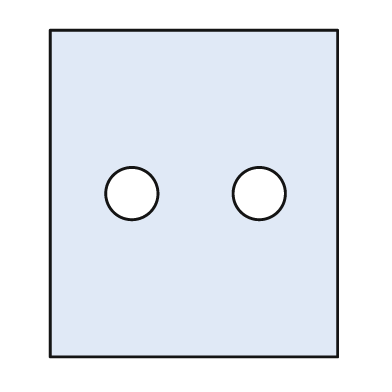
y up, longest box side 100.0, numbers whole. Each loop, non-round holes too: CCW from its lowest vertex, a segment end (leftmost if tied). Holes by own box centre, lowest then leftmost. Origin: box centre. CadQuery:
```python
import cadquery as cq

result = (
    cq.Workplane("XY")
    .moveTo(-44.0, -50.0)
    .lineTo(44.0, -50.0)
    .lineTo(44.0, 50.0)
    .lineTo(-44.0, 50.0)
    .close()
    .moveTo(-19.0, 0.0)
    .circle(8.0)
    .moveTo(20.0, 0.0)
    .circle(8.0)
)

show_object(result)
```